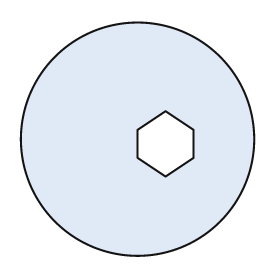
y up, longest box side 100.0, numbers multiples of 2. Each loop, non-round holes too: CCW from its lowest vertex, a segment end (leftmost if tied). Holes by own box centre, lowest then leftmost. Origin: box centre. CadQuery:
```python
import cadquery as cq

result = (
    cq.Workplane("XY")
    .moveTo(0.0, 0.0)
    .circle(50.0)
    .moveTo(12.0, -16.0)
    .lineTo(24.0, -8.0)
    .lineTo(24.0, 4.0)
    .lineTo(12.0, 12.0)
    .lineTo(0.0, 4.0)
    .lineTo(0.0, -8.0)
    .close()
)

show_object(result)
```